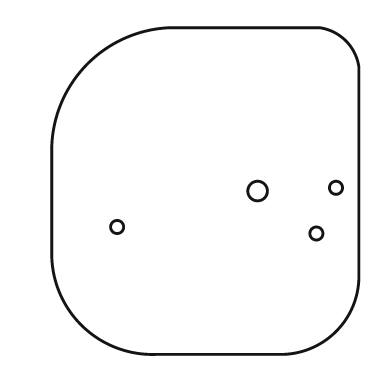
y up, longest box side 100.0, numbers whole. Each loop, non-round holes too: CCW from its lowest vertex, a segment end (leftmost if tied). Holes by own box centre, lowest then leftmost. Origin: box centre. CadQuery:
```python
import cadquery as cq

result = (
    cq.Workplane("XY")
    .moveTo(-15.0, -50.0)
    .lineTo(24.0, -50.0)
    .threePointArc((40.0, -43.0), (47.0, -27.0))
    .lineTo(47.0, 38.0)
    .threePointArc((43.0, 46.0), (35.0, 50.0))
    .lineTo(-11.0, 50.0)
    .threePointArc((-36.0, 39.0), (-47.0, 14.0))
    .lineTo(-47.0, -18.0)
    .threePointArc((-38.0, -41.0), (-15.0, -50.0))
    .close()
    .moveTo(34.0, -13.0)
    .circle(2.0)
    .moveTo(-27.0, -11.0)
    .circle(2.0)
    .moveTo(16.0, 0.0)
    .circle(3.0)
    .moveTo(40.0, 1.0)
    .circle(2.0)
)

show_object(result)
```